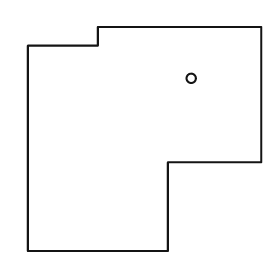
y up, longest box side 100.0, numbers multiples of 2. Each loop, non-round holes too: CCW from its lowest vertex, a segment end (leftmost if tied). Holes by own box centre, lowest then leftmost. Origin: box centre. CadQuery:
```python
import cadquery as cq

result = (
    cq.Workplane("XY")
    .moveTo(-50.0, -48.0)
    .lineTo(10.0, -48.0)
    .lineTo(10.0, -10.0)
    .lineTo(50.0, -10.0)
    .lineTo(50.0, 48.0)
    .lineTo(-20.0, 48.0)
    .lineTo(-20.0, 40.0)
    .lineTo(-50.0, 40.0)
    .close()
    .moveTo(20.0, 26.0)
    .circle(2.0)
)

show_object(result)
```